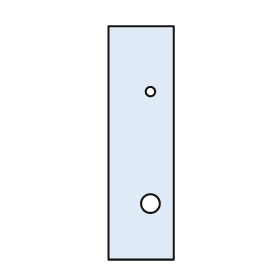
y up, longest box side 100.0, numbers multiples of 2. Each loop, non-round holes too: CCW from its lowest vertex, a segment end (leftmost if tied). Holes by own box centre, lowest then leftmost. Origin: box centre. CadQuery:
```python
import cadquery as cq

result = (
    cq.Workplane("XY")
    .moveTo(-14.0, -50.0)
    .lineTo(14.0, -50.0)
    .lineTo(14.0, 50.0)
    .lineTo(-14.0, 50.0)
    .close()
    .moveTo(4.0, -26.0)
    .circle(4.0)
    .moveTo(4.0, 22.0)
    .circle(2.0)
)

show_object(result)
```